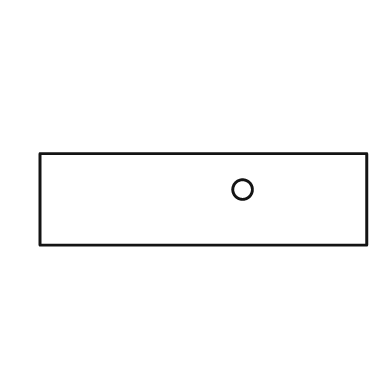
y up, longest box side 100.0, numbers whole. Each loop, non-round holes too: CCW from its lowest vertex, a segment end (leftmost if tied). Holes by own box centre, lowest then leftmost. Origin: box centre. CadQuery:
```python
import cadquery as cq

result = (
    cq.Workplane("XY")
    .moveTo(-50.0, -14.0)
    .lineTo(50.0, -14.0)
    .lineTo(50.0, 14.0)
    .lineTo(-50.0, 14.0)
    .close()
    .moveTo(12.0, 3.0)
    .circle(3.0)
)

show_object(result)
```